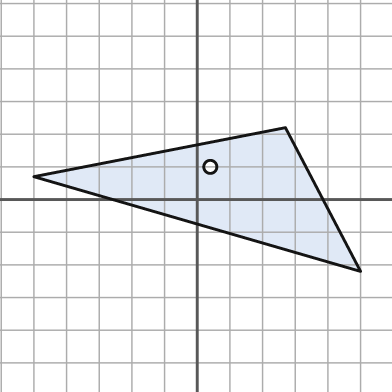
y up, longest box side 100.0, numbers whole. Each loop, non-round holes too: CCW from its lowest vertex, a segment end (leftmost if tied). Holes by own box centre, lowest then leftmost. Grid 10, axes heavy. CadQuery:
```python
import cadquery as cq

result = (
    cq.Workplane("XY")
    .moveTo(50.0, -22.0)
    .lineTo(27.0, 22.0)
    .lineTo(-50.0, 7.0)
    .close()
    .moveTo(4.0, 10.0)
    .circle(2.0)
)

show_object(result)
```